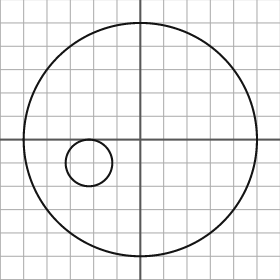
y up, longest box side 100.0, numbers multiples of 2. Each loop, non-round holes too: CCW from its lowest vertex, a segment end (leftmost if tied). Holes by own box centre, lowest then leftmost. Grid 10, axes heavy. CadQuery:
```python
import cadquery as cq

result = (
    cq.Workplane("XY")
    .moveTo(0.0, 0.0)
    .circle(50.0)
    .moveTo(-22.0, -10.0)
    .circle(10.0)
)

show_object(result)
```